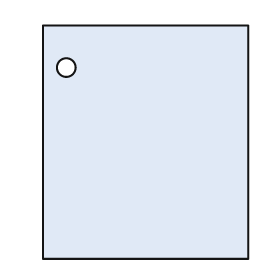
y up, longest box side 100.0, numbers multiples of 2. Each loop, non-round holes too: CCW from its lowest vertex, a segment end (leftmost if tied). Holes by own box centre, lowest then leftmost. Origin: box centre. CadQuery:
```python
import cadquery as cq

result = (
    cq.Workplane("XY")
    .moveTo(-44.0, -50.0)
    .lineTo(44.0, -50.0)
    .lineTo(44.0, 50.0)
    .lineTo(-44.0, 50.0)
    .close()
    .moveTo(-34.0, 32.0)
    .circle(4.0)
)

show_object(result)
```